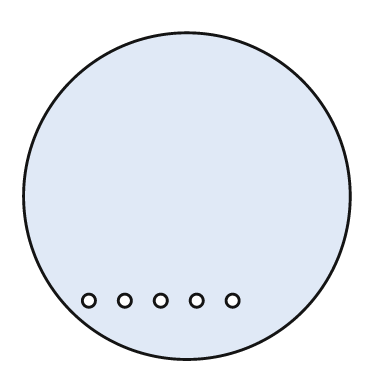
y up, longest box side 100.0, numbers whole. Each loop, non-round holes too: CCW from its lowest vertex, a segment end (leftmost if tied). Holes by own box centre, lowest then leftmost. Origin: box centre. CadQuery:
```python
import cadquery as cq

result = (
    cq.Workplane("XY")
    .moveTo(0.0, 0.0)
    .circle(50.0)
    .moveTo(-30.0, -32.0)
    .circle(2.0)
    .moveTo(-19.0, -32.0)
    .circle(2.0)
    .moveTo(-8.0, -32.0)
    .circle(2.0)
    .moveTo(3.0, -32.0)
    .circle(2.0)
    .moveTo(14.0, -32.0)
    .circle(2.0)
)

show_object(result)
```